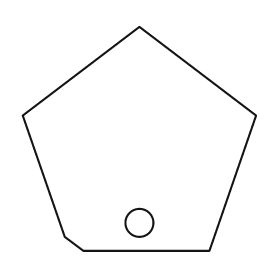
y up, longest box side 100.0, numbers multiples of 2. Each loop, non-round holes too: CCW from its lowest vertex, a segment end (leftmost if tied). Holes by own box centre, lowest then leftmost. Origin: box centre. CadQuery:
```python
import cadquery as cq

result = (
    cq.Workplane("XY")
    .moveTo(-24.0, -48.0)
    .lineTo(30.0, -48.0)
    .lineTo(50.0, 10.0)
    .lineTo(0.0, 48.0)
    .lineTo(-50.0, 10.0)
    .lineTo(-32.0, -42.0)
    .close()
    .moveTo(0.0, -36.0)
    .circle(6.0)
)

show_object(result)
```